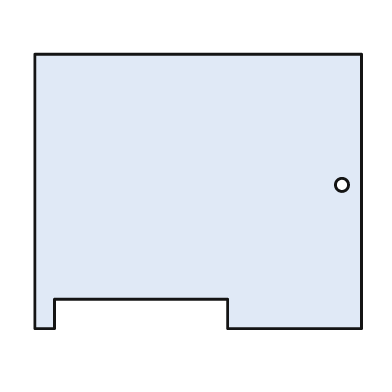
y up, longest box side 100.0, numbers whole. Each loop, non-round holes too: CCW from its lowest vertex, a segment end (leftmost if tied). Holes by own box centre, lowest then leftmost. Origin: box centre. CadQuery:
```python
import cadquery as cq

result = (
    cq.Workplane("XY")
    .moveTo(-50.0, -42.0)
    .lineTo(-44.0, -42.0)
    .lineTo(-44.0, -33.0)
    .lineTo(9.0, -33.0)
    .lineTo(9.0, -42.0)
    .lineTo(50.0, -42.0)
    .lineTo(50.0, 42.0)
    .lineTo(-50.0, 42.0)
    .close()
    .moveTo(44.0, 2.0)
    .circle(2.0)
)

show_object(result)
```